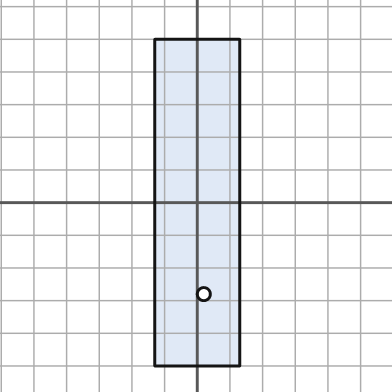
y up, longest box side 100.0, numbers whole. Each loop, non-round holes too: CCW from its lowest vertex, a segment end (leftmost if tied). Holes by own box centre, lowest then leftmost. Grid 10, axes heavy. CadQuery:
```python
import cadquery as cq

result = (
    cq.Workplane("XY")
    .moveTo(-13.0, -50.0)
    .lineTo(13.0, -50.0)
    .lineTo(13.0, 50.0)
    .lineTo(-13.0, 50.0)
    .close()
    .moveTo(2.0, -28.0)
    .circle(2.0)
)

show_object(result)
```